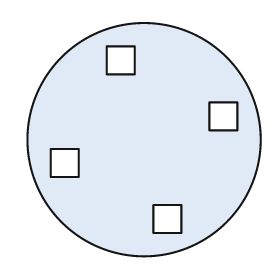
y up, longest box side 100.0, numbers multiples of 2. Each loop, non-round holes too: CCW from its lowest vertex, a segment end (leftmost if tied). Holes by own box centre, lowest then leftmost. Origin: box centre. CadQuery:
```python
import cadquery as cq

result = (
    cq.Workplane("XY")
    .moveTo(0.0, 0.0)
    .circle(50.0)
    .moveTo(4.0, -40.0)
    .lineTo(16.0, -40.0)
    .lineTo(16.0, -28.0)
    .lineTo(4.0, -28.0)
    .close()
    .moveTo(-40.0, -16.0)
    .lineTo(-28.0, -16.0)
    .lineTo(-28.0, -4.0)
    .lineTo(-40.0, -4.0)
    .close()
    .moveTo(28.0, 4.0)
    .lineTo(40.0, 4.0)
    .lineTo(40.0, 16.0)
    .lineTo(28.0, 16.0)
    .close()
    .moveTo(-16.0, 28.0)
    .lineTo(-4.0, 28.0)
    .lineTo(-4.0, 40.0)
    .lineTo(-16.0, 40.0)
    .close()
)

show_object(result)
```